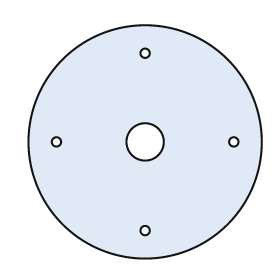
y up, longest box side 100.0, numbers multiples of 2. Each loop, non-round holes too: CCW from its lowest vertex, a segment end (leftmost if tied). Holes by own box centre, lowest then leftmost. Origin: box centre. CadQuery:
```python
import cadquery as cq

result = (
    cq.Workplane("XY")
    .moveTo(0.0, 0.0)
    .circle(50.0)
    .moveTo(0.0, -38.0)
    .circle(2.0)
    .moveTo(-38.0, 0.0)
    .circle(2.0)
    .moveTo(0.0, 0.0)
    .circle(8.0)
    .moveTo(38.0, 0.0)
    .circle(2.0)
    .moveTo(0.0, 38.0)
    .circle(2.0)
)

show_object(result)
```